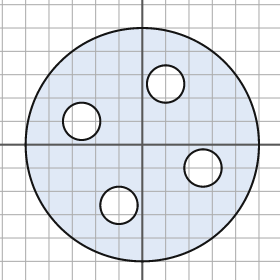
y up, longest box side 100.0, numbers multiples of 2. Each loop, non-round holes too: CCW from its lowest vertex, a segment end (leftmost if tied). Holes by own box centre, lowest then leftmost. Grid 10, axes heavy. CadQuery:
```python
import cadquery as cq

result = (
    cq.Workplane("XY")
    .moveTo(0.0, 0.0)
    .circle(50.0)
    .moveTo(-10.0, -26.0)
    .circle(8.0)
    .moveTo(26.0, -10.0)
    .circle(8.0)
    .moveTo(-26.0, 10.0)
    .circle(8.0)
    .moveTo(10.0, 26.0)
    .circle(8.0)
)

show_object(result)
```